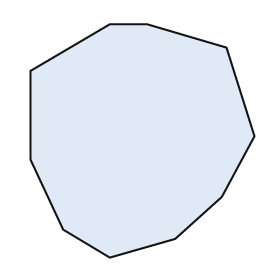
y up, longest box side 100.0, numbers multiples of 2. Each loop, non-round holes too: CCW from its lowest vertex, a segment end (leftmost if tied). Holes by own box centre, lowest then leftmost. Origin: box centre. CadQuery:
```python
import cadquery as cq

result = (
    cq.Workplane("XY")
    .moveTo(-14.0, -50.0)
    .lineTo(14.0, -42.0)
    .lineTo(34.0, -24.0)
    .lineTo(48.0, 2.0)
    .lineTo(36.0, 40.0)
    .lineTo(2.0, 50.0)
    .lineTo(-14.0, 50.0)
    .lineTo(-48.0, 30.0)
    .lineTo(-48.0, -8.0)
    .lineTo(-34.0, -38.0)
    .close()
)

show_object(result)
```